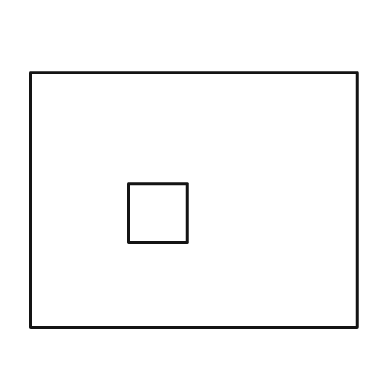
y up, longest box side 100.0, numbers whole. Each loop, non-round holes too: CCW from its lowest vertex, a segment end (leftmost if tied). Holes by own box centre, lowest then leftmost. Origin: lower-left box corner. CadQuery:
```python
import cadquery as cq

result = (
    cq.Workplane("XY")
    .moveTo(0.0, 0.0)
    .lineTo(100.0, 0.0)
    .lineTo(100.0, 78.0)
    .lineTo(0.0, 78.0)
    .close()
    .moveTo(30.0, 26.0)
    .lineTo(48.0, 26.0)
    .lineTo(48.0, 44.0)
    .lineTo(30.0, 44.0)
    .close()
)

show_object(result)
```